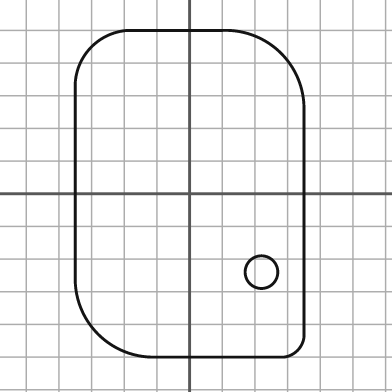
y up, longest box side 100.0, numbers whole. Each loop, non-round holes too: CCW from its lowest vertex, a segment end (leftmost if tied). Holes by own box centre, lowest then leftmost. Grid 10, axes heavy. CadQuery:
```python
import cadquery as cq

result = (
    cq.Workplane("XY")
    .moveTo(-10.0, -50.0)
    .lineTo(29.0, -50.0)
    .threePointArc((33.0, -48.0), (35.0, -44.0))
    .lineTo(35.0, 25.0)
    .threePointArc((28.0, 43.0), (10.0, 50.0))
    .lineTo(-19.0, 50.0)
    .threePointArc((-30.0, 45.0), (-35.0, 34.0))
    .lineTo(-35.0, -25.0)
    .threePointArc((-28.0, -43.0), (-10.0, -50.0))
    .close()
    .moveTo(22.0, -24.0)
    .circle(5.0)
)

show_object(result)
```